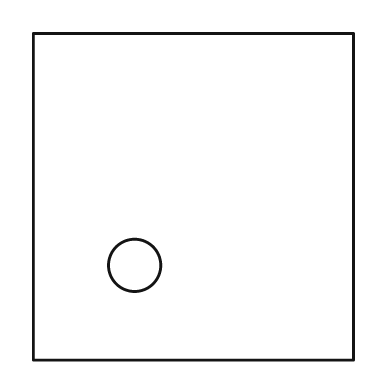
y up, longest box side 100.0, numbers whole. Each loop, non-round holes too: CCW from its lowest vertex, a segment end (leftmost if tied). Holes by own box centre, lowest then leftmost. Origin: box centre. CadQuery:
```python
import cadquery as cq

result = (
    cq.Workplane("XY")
    .moveTo(-49.0, -50.0)
    .lineTo(49.0, -50.0)
    .lineTo(49.0, 50.0)
    .lineTo(-49.0, 50.0)
    .close()
    .moveTo(-18.0, -21.0)
    .circle(8.0)
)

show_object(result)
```